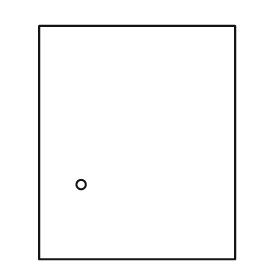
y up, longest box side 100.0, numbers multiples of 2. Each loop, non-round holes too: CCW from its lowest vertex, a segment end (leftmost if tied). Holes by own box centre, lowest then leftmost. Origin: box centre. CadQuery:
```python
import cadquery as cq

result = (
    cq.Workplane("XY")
    .moveTo(-42.0, -50.0)
    .lineTo(42.0, -50.0)
    .lineTo(42.0, 50.0)
    .lineTo(-42.0, 50.0)
    .close()
    .moveTo(-24.0, -18.0)
    .circle(2.0)
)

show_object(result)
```